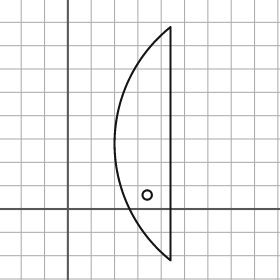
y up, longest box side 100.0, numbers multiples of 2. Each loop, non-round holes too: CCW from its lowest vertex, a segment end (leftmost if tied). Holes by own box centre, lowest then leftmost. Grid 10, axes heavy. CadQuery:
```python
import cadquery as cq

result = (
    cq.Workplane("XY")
    .moveTo(44.0, -22.0)
    .lineTo(44.0, 78.0)
    .threePointArc((20.0, 28.0), (44.0, -22.0))
    .close()
    .moveTo(34.0, 6.0)
    .circle(2.0)
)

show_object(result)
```